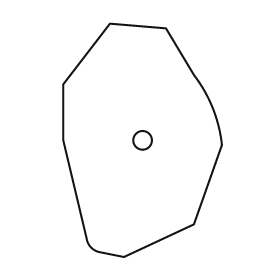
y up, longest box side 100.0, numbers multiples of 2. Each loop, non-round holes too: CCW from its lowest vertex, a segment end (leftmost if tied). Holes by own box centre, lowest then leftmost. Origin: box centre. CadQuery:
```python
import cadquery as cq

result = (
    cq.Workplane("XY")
    .moveTo(-8.0, -50.0)
    .lineTo(22.0, -36.0)
    .lineTo(34.0, -2.0)
    .threePointArc((30.0, 14.0), (22.0, 28.0))
    .lineTo(10.0, 48.0)
    .lineTo(-14.0, 50.0)
    .lineTo(-34.0, 24.0)
    .lineTo(-34.0, 0.0)
    .lineTo(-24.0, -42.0)
    .threePointArc((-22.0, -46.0), (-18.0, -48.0))
    .close()
    .moveTo(0.0, 0.0)
    .circle(4.0)
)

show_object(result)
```